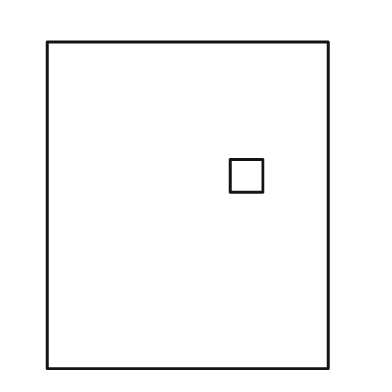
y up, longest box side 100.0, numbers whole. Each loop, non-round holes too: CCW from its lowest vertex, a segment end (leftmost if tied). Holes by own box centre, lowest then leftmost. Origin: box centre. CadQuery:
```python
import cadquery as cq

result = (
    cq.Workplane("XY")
    .moveTo(-43.0, -50.0)
    .lineTo(43.0, -50.0)
    .lineTo(43.0, 50.0)
    .lineTo(-43.0, 50.0)
    .close()
    .moveTo(13.0, 4.0)
    .lineTo(23.0, 4.0)
    .lineTo(23.0, 14.0)
    .lineTo(13.0, 14.0)
    .close()
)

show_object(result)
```